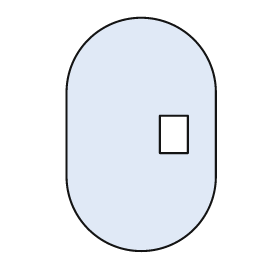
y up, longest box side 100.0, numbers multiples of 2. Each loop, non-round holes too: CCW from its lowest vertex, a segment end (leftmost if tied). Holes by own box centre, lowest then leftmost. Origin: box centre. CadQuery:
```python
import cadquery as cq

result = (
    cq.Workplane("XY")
    .moveTo(-32.0, -18.0)
    .threePointArc((0.0, -50.0), (32.0, -18.0))
    .lineTo(32.0, 18.0)
    .threePointArc((0.0, 50.0), (-32.0, 18.0))
    .close()
    .moveTo(8.0, -8.0)
    .lineTo(20.0, -8.0)
    .lineTo(20.0, 8.0)
    .lineTo(8.0, 8.0)
    .close()
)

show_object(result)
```